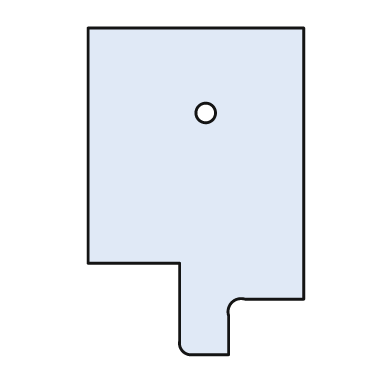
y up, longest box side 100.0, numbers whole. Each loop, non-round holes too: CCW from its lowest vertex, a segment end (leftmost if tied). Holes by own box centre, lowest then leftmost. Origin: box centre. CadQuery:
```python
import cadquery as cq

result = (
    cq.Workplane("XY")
    .moveTo(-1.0, -50.0)
    .lineTo(10.0, -50.0)
    .lineTo(10.0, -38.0)
    .threePointArc((11.0, -34.0), (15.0, -33.0))
    .lineTo(33.0, -33.0)
    .lineTo(33.0, 50.0)
    .lineTo(-33.0, 50.0)
    .lineTo(-33.0, -22.0)
    .lineTo(-5.0, -22.0)
    .lineTo(-5.0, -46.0)
    .threePointArc((-4.0, -49.0), (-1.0, -50.0))
    .close()
    .moveTo(3.0, 24.0)
    .circle(3.0)
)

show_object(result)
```